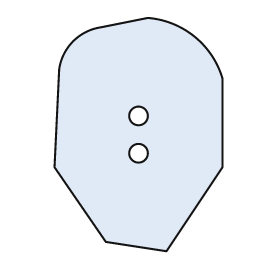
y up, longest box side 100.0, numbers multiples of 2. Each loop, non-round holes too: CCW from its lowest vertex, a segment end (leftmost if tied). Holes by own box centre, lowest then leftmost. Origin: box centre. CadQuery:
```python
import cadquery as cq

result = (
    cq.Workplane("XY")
    .moveTo(12.0, -50.0)
    .lineTo(36.0, -14.0)
    .lineTo(36.0, 24.0)
    .threePointArc((24.0, 42.0), (4.0, 50.0))
    .lineTo(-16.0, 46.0)
    .threePointArc((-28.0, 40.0), (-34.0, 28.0))
    .lineTo(-36.0, -14.0)
    .lineTo(-14.0, -46.0)
    .close()
    .moveTo(0.0, -8.0)
    .circle(4.0)
    .moveTo(0.0, 8.0)
    .circle(4.0)
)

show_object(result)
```